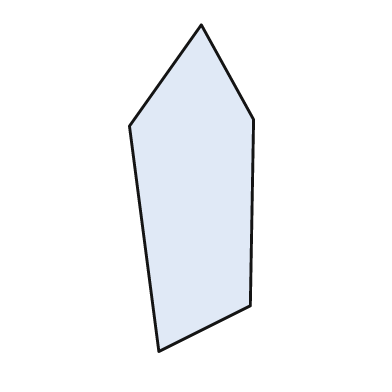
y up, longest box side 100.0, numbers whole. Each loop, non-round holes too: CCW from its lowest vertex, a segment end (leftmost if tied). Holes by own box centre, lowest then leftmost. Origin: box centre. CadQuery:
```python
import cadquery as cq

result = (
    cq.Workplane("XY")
    .moveTo(-10.0, -50.0)
    .lineTo(18.0, -36.0)
    .lineTo(19.0, 21.0)
    .lineTo(3.0, 50.0)
    .lineTo(-19.0, 19.0)
    .close()
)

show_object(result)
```